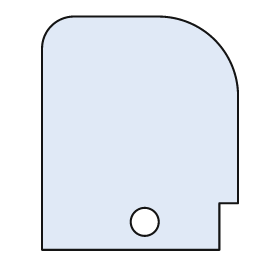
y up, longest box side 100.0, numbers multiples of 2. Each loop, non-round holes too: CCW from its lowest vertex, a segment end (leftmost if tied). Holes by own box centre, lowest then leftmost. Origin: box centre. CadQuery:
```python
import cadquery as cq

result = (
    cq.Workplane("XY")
    .moveTo(-42.0, -50.0)
    .lineTo(34.0, -50.0)
    .lineTo(34.0, -30.0)
    .lineTo(42.0, -30.0)
    .lineTo(42.0, 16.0)
    .threePointArc((32.0, 40.0), (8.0, 50.0))
    .lineTo(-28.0, 50.0)
    .threePointArc((-38.0, 46.0), (-42.0, 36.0))
    .close()
    .moveTo(2.0, -38.0)
    .circle(6.0)
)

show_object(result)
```